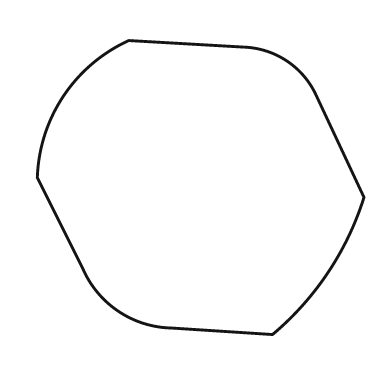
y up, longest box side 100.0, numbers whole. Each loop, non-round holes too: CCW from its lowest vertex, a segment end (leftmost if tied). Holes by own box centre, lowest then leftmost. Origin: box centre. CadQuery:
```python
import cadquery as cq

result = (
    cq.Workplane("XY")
    .moveTo(22.0, -45.0)
    .threePointArc((39.0, -26.0), (50.0, -3.0))
    .lineTo(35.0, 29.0)
    .threePointArc((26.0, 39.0), (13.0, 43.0))
    .lineTo(-22.0, 45.0)
    .threePointArc((-42.0, 28.0), (-50.0, 3.0))
    .lineTo(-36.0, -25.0)
    .threePointArc((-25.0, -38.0), (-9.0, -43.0))
    .close()
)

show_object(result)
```